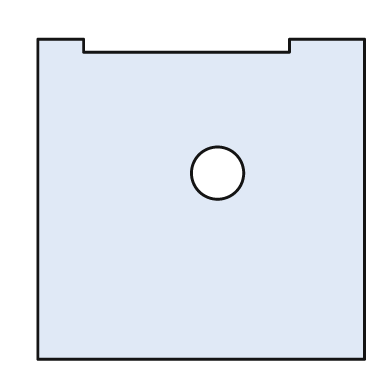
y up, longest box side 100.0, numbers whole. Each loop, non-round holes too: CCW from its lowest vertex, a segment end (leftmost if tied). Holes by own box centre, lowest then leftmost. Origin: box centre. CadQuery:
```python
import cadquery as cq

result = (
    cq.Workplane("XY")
    .moveTo(-50.0, -49.0)
    .lineTo(50.0, -49.0)
    .lineTo(50.0, 49.0)
    .lineTo(27.0, 49.0)
    .lineTo(27.0, 45.0)
    .lineTo(-36.0, 45.0)
    .lineTo(-36.0, 49.0)
    .lineTo(-50.0, 49.0)
    .close()
    .moveTo(5.0, 8.0)
    .circle(8.0)
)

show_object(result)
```